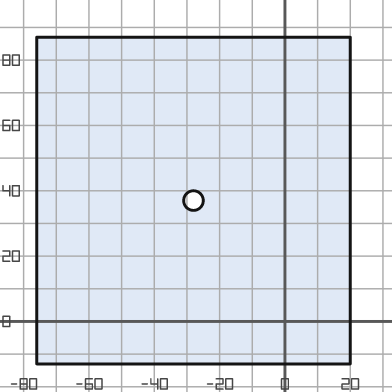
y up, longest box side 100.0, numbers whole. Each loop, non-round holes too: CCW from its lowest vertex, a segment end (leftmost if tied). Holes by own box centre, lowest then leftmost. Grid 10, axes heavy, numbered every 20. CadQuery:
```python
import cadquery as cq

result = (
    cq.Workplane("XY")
    .moveTo(-76.0, -13.0)
    .lineTo(20.0, -13.0)
    .lineTo(20.0, 87.0)
    .lineTo(-76.0, 87.0)
    .close()
    .moveTo(-28.0, 37.0)
    .circle(3.0)
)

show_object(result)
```